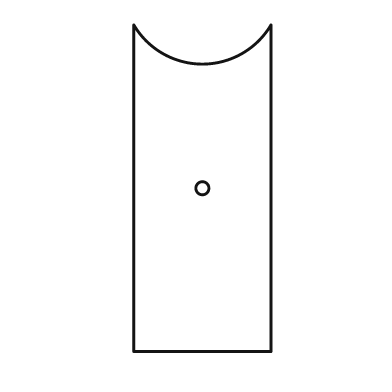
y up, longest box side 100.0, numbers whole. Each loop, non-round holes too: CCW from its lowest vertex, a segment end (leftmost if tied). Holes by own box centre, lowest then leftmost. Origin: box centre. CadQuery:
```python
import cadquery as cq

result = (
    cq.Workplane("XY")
    .moveTo(-21.0, -50.0)
    .lineTo(21.0, -50.0)
    .lineTo(21.0, 50.0)
    .threePointArc((0.0, 38.0), (-21.0, 50.0))
    .close()
    .moveTo(0.0, 0.0)
    .circle(2.0)
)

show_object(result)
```